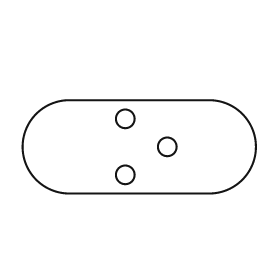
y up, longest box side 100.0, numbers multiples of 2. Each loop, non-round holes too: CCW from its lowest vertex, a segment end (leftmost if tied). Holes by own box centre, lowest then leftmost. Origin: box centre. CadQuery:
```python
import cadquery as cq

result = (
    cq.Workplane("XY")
    .moveTo(-30.0, -20.0)
    .lineTo(30.0, -20.0)
    .threePointArc((50.0, 0.0), (30.0, 20.0))
    .lineTo(-30.0, 20.0)
    .threePointArc((-50.0, 0.0), (-30.0, -20.0))
    .close()
    .moveTo(-6.0, -12.0)
    .circle(4.0)
    .moveTo(12.0, 0.0)
    .circle(4.0)
    .moveTo(-6.0, 12.0)
    .circle(4.0)
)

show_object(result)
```